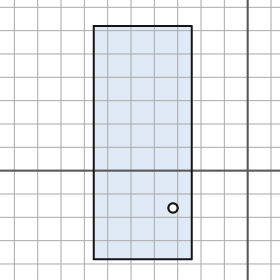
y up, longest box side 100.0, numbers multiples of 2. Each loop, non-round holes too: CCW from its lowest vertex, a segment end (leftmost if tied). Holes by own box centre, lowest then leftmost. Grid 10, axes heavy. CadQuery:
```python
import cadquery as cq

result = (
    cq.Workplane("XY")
    .moveTo(-66.0, -38.0)
    .lineTo(-24.0, -38.0)
    .lineTo(-24.0, 62.0)
    .lineTo(-66.0, 62.0)
    .close()
    .moveTo(-32.0, -16.0)
    .circle(2.0)
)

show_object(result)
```